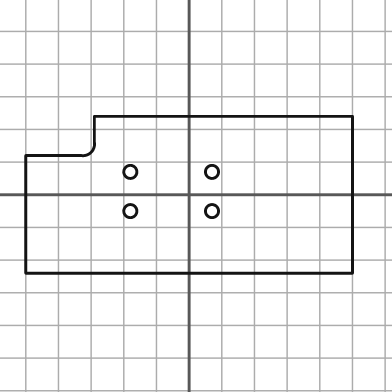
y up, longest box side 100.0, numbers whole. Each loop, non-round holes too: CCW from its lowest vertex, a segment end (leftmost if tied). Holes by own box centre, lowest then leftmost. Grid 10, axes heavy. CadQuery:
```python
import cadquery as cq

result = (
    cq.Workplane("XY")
    .moveTo(-50.0, -24.0)
    .lineTo(50.0, -24.0)
    .lineTo(50.0, 24.0)
    .lineTo(-29.0, 24.0)
    .lineTo(-29.0, 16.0)
    .threePointArc((-30.0, 13.0), (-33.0, 12.0))
    .lineTo(-50.0, 12.0)
    .close()
    .moveTo(-18.0, -5.0)
    .circle(2.0)
    .moveTo(7.0, -5.0)
    .circle(2.0)
    .moveTo(-18.0, 7.0)
    .circle(2.0)
    .moveTo(7.0, 7.0)
    .circle(2.0)
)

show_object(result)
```